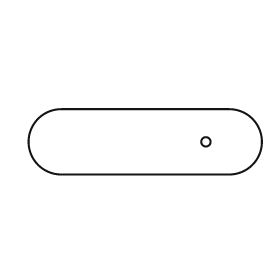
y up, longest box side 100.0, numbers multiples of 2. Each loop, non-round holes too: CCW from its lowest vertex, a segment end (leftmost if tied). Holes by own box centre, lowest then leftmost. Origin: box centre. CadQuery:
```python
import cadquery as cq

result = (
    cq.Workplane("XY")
    .moveTo(-36.0, -14.0)
    .lineTo(36.0, -14.0)
    .threePointArc((50.0, 0.0), (36.0, 14.0))
    .lineTo(-36.0, 14.0)
    .threePointArc((-50.0, 0.0), (-36.0, -14.0))
    .close()
    .moveTo(26.0, 0.0)
    .circle(2.0)
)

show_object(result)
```